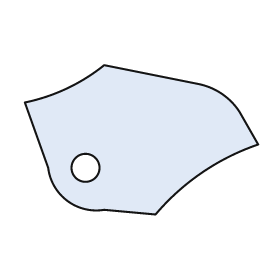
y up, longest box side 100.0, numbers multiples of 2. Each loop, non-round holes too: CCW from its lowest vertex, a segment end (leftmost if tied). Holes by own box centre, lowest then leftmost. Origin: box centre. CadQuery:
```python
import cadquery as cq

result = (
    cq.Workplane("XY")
    .moveTo(6.0, -32.0)
    .threePointArc((26.0, -14.0), (50.0, -2.0))
    .lineTo(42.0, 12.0)
    .threePointArc((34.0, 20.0), (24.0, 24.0))
    .lineTo(-16.0, 32.0)
    .threePointArc((-32.0, 22.0), (-50.0, 16.0))
    .lineTo(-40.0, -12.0)
    .threePointArc((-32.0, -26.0), (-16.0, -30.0))
    .close()
    .moveTo(-24.0, -12.0)
    .circle(6.0)
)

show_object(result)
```